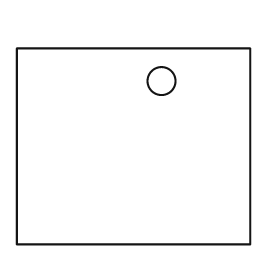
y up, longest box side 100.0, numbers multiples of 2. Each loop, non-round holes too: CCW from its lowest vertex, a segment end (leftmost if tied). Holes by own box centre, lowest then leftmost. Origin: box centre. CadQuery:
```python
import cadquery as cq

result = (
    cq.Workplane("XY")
    .moveTo(-50.0, -42.0)
    .lineTo(50.0, -42.0)
    .lineTo(50.0, 42.0)
    .lineTo(-50.0, 42.0)
    .close()
    .moveTo(12.0, 28.0)
    .circle(6.0)
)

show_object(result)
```